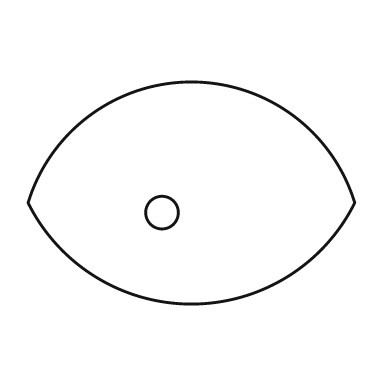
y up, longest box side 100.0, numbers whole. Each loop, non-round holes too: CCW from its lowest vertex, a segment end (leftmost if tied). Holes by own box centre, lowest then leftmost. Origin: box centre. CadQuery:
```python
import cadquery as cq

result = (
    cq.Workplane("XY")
    .moveTo(-50.0, -3.0)
    .threePointArc((0.0, -34.0), (50.0, -3.0))
    .threePointArc((0.0, 34.0), (-50.0, -3.0))
    .close()
    .moveTo(-9.0, -6.0)
    .circle(5.0)
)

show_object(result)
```